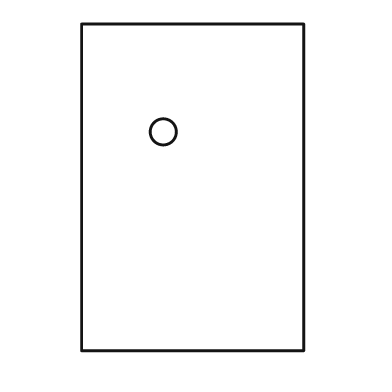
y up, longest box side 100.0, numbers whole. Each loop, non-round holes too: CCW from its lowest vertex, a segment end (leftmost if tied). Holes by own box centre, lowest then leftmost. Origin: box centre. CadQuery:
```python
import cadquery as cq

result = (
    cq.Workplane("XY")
    .moveTo(-34.0, -50.0)
    .lineTo(34.0, -50.0)
    .lineTo(34.0, 50.0)
    .lineTo(-34.0, 50.0)
    .close()
    .moveTo(-9.0, 17.0)
    .circle(4.0)
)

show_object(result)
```